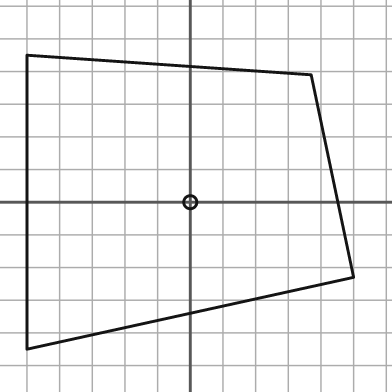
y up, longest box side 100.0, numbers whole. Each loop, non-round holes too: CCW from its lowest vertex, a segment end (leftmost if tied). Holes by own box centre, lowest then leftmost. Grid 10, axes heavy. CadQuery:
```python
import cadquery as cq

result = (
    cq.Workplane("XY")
    .moveTo(-50.0, -45.0)
    .lineTo(50.0, -23.0)
    .lineTo(37.0, 39.0)
    .lineTo(-50.0, 45.0)
    .close()
    .moveTo(0.0, 0.0)
    .circle(2.0)
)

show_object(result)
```